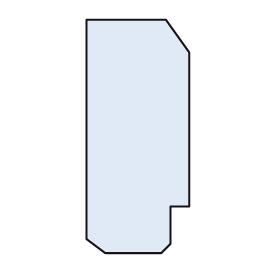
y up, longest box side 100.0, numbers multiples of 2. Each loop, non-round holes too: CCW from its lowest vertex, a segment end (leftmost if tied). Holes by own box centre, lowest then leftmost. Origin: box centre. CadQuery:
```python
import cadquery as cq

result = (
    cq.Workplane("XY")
    .moveTo(-14.0, -50.0)
    .lineTo(10.0, -50.0)
    .lineTo(14.0, -46.0)
    .lineTo(14.0, -30.0)
    .lineTo(22.0, -30.0)
    .lineTo(22.0, 36.0)
    .lineTo(12.0, 50.0)
    .lineTo(-22.0, 50.0)
    .lineTo(-22.0, -44.0)
    .close()
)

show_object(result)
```